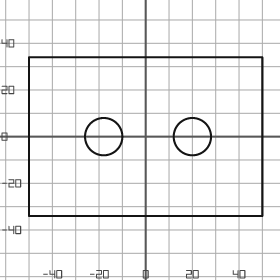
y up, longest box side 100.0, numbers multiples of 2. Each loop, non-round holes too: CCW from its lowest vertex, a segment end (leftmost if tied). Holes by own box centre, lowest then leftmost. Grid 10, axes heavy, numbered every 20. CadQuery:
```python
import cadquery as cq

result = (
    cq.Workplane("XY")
    .moveTo(-50.0, -34.0)
    .lineTo(50.0, -34.0)
    .lineTo(50.0, 34.0)
    .lineTo(-50.0, 34.0)
    .close()
    .moveTo(-18.0, 0.0)
    .circle(8.0)
    .moveTo(20.0, 0.0)
    .circle(8.0)
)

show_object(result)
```